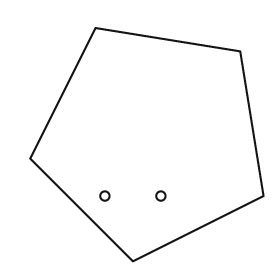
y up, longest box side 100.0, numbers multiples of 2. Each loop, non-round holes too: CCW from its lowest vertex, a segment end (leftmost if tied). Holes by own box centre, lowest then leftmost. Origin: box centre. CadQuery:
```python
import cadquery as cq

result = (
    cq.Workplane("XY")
    .moveTo(-6.0, -50.0)
    .lineTo(50.0, -22.0)
    .lineTo(40.0, 40.0)
    .lineTo(-22.0, 50.0)
    .lineTo(-50.0, -6.0)
    .close()
    .moveTo(-18.0, -22.0)
    .circle(2.0)
    .moveTo(6.0, -22.0)
    .circle(2.0)
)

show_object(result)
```